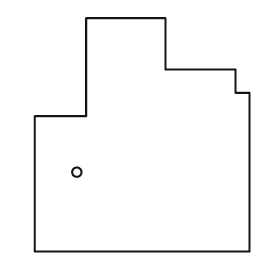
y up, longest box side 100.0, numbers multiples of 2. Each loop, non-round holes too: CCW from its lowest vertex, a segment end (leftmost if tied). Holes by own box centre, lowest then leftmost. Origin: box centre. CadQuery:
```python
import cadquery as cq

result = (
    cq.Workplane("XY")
    .moveTo(-46.0, -50.0)
    .lineTo(46.0, -50.0)
    .lineTo(46.0, 18.0)
    .lineTo(40.0, 18.0)
    .lineTo(40.0, 28.0)
    .lineTo(10.0, 28.0)
    .lineTo(10.0, 50.0)
    .lineTo(-24.0, 50.0)
    .lineTo(-24.0, 8.0)
    .lineTo(-46.0, 8.0)
    .close()
    .moveTo(-28.0, -16.0)
    .circle(2.0)
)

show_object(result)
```